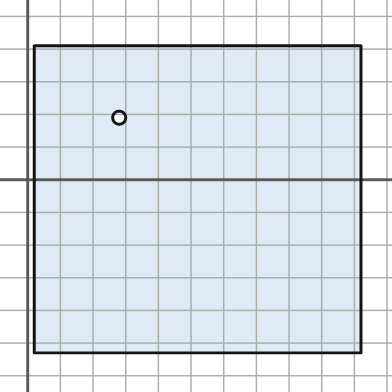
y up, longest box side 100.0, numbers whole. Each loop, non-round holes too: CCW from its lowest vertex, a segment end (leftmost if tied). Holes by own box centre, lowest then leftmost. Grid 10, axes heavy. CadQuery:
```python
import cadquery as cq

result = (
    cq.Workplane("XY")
    .moveTo(2.0, -53.0)
    .lineTo(102.0, -53.0)
    .lineTo(102.0, 41.0)
    .lineTo(2.0, 41.0)
    .close()
    .moveTo(28.0, 19.0)
    .circle(2.0)
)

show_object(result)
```